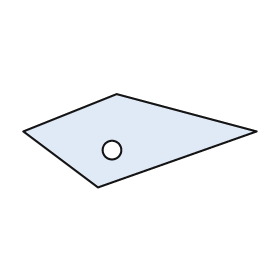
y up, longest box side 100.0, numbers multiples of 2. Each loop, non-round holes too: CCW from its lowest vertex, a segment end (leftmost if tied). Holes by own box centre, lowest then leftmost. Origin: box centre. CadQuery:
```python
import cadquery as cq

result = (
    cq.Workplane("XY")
    .moveTo(-18.0, -20.0)
    .lineTo(50.0, 4.0)
    .lineTo(-10.0, 20.0)
    .lineTo(-50.0, 4.0)
    .close()
    .moveTo(-12.0, -4.0)
    .circle(4.0)
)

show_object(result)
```